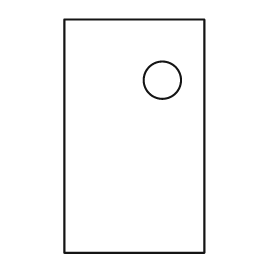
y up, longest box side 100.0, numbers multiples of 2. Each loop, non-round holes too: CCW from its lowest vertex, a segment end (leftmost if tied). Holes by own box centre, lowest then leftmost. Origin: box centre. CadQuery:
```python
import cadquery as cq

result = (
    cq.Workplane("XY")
    .moveTo(-30.0, -50.0)
    .lineTo(30.0, -50.0)
    .lineTo(30.0, 50.0)
    .lineTo(-30.0, 50.0)
    .close()
    .moveTo(12.0, 24.0)
    .circle(8.0)
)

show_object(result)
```